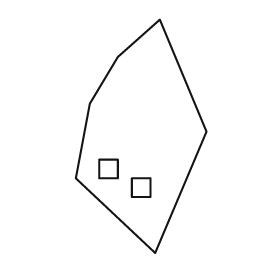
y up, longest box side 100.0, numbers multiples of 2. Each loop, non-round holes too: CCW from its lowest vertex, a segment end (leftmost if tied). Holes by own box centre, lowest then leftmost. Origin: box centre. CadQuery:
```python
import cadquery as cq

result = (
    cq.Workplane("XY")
    .moveTo(6.0, -50.0)
    .lineTo(28.0, 2.0)
    .lineTo(8.0, 50.0)
    .lineTo(-10.0, 34.0)
    .lineTo(-22.0, 14.0)
    .lineTo(-28.0, -18.0)
    .close()
    .moveTo(-4.0, -26.0)
    .lineTo(4.0, -26.0)
    .lineTo(4.0, -18.0)
    .lineTo(-4.0, -18.0)
    .close()
    .moveTo(-18.0, -18.0)
    .lineTo(-10.0, -18.0)
    .lineTo(-10.0, -10.0)
    .lineTo(-18.0, -10.0)
    .close()
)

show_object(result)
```